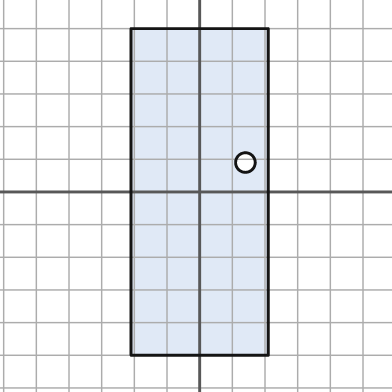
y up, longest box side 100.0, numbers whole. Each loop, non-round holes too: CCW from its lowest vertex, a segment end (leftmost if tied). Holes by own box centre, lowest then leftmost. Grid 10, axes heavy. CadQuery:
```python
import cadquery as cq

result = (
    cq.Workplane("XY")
    .moveTo(-21.0, -50.0)
    .lineTo(21.0, -50.0)
    .lineTo(21.0, 50.0)
    .lineTo(-21.0, 50.0)
    .close()
    .moveTo(14.0, 9.0)
    .circle(3.0)
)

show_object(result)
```